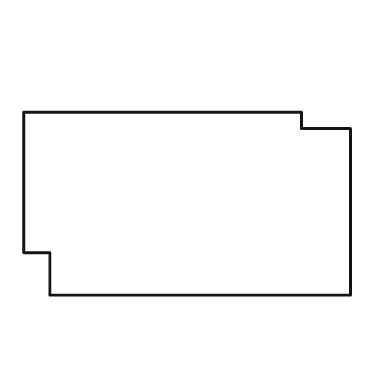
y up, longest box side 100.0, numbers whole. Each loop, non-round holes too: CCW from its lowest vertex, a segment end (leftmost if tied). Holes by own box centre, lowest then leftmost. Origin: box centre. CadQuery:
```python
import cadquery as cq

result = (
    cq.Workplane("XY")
    .moveTo(-42.0, -28.0)
    .lineTo(50.0, -28.0)
    .lineTo(50.0, 23.0)
    .lineTo(35.0, 23.0)
    .lineTo(35.0, 28.0)
    .lineTo(-50.0, 28.0)
    .lineTo(-50.0, -15.0)
    .lineTo(-42.0, -15.0)
    .close()
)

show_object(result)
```